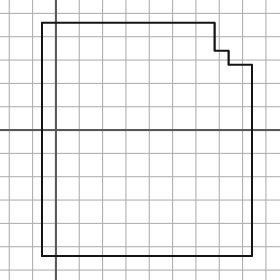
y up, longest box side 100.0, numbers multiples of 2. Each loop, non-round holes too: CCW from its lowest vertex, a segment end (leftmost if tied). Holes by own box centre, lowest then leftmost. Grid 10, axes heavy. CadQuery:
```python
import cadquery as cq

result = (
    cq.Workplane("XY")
    .moveTo(-6.0, -54.0)
    .lineTo(84.0, -54.0)
    .lineTo(84.0, 28.0)
    .lineTo(74.0, 28.0)
    .lineTo(74.0, 34.0)
    .lineTo(68.0, 34.0)
    .lineTo(68.0, 46.0)
    .lineTo(-6.0, 46.0)
    .close()
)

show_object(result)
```